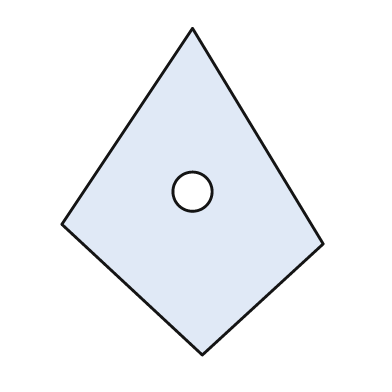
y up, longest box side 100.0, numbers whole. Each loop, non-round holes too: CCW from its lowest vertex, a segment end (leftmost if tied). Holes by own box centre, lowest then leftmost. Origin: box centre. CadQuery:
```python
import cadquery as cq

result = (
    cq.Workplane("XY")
    .moveTo(3.0, -50.0)
    .lineTo(40.0, -16.0)
    .lineTo(0.0, 50.0)
    .lineTo(-40.0, -10.0)
    .close()
    .moveTo(0.0, 0.0)
    .circle(6.0)
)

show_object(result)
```